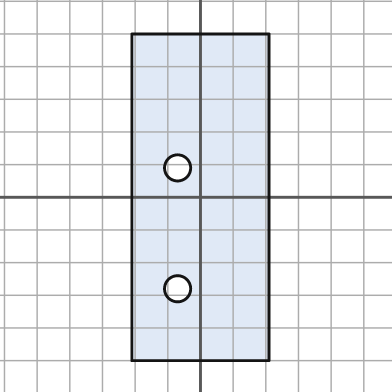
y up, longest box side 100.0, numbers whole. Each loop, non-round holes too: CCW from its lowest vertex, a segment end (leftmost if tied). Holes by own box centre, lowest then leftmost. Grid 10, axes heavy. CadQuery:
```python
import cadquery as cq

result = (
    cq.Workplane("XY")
    .moveTo(-21.0, -50.0)
    .lineTo(21.0, -50.0)
    .lineTo(21.0, 50.0)
    .lineTo(-21.0, 50.0)
    .close()
    .moveTo(-7.0, -28.0)
    .circle(4.0)
    .moveTo(-7.0, 9.0)
    .circle(4.0)
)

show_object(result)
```